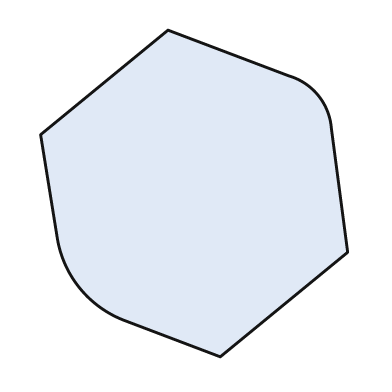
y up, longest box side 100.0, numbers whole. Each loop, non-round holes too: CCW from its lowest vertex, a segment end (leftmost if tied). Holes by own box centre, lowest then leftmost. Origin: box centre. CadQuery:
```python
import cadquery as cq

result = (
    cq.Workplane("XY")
    .moveTo(8.0, -50.0)
    .lineTo(47.0, -18.0)
    .lineTo(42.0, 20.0)
    .threePointArc((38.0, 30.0), (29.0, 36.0))
    .lineTo(-8.0, 50.0)
    .lineTo(-47.0, 18.0)
    .lineTo(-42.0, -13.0)
    .threePointArc((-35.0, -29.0), (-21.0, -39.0))
    .close()
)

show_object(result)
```